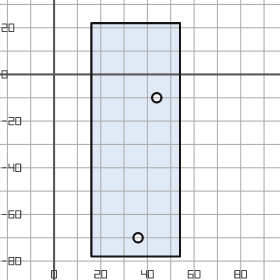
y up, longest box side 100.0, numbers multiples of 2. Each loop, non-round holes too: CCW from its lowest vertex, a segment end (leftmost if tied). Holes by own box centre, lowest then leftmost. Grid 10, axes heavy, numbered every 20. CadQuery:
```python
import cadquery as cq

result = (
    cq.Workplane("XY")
    .moveTo(16.0, -78.0)
    .lineTo(54.0, -78.0)
    .lineTo(54.0, 22.0)
    .lineTo(16.0, 22.0)
    .close()
    .moveTo(36.0, -70.0)
    .circle(2.0)
    .moveTo(44.0, -10.0)
    .circle(2.0)
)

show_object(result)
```